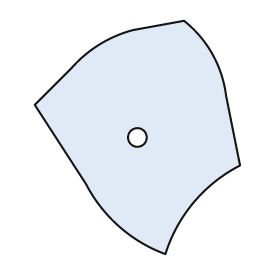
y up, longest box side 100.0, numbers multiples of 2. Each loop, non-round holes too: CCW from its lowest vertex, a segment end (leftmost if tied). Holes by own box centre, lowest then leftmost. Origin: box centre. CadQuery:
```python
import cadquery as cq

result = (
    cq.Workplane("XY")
    .moveTo(12.0, -50.0)
    .threePointArc((24.0, -28.0), (44.0, -12.0))
    .lineTo(38.0, 18.0)
    .threePointArc((32.0, 36.0), (20.0, 50.0))
    .lineTo(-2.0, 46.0)
    .threePointArc((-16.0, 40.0), (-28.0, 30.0))
    .lineTo(-44.0, 14.0)
    .lineTo(-22.0, -20.0)
    .threePointArc((-8.0, -38.0), (12.0, -50.0))
    .close()
    .moveTo(0.0, 0.0)
    .circle(4.0)
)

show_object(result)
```